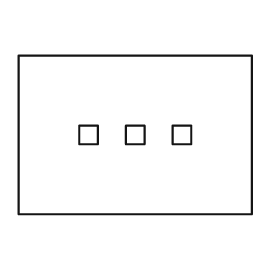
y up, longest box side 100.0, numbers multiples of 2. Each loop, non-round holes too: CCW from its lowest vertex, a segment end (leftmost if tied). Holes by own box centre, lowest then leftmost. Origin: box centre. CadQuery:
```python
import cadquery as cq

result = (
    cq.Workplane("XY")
    .moveTo(-50.0, -34.0)
    .lineTo(50.0, -34.0)
    .lineTo(50.0, 34.0)
    .lineTo(-50.0, 34.0)
    .close()
    .moveTo(-24.0, -4.0)
    .lineTo(-16.0, -4.0)
    .lineTo(-16.0, 4.0)
    .lineTo(-24.0, 4.0)
    .close()
    .moveTo(-4.0, -4.0)
    .lineTo(4.0, -4.0)
    .lineTo(4.0, 4.0)
    .lineTo(-4.0, 4.0)
    .close()
    .moveTo(16.0, -4.0)
    .lineTo(24.0, -4.0)
    .lineTo(24.0, 4.0)
    .lineTo(16.0, 4.0)
    .close()
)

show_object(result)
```